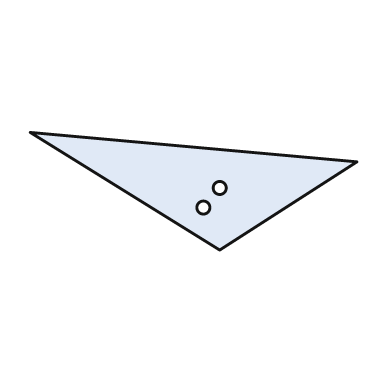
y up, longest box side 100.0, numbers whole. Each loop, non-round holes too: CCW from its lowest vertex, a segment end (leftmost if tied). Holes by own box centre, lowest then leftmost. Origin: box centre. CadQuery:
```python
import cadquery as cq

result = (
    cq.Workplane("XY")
    .moveTo(8.0, -18.0)
    .lineTo(50.0, 9.0)
    .lineTo(-50.0, 18.0)
    .close()
    .moveTo(3.0, -5.0)
    .circle(2.0)
    .moveTo(8.0, 1.0)
    .circle(2.0)
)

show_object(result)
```